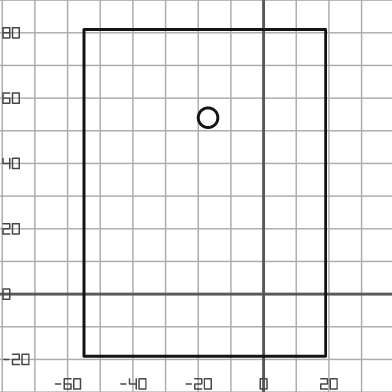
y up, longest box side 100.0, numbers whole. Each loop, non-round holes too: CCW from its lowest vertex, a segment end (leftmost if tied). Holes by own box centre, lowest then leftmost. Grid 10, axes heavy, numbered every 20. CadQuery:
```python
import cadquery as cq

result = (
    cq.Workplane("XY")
    .moveTo(-55.0, -19.0)
    .lineTo(19.0, -19.0)
    .lineTo(19.0, 81.0)
    .lineTo(-55.0, 81.0)
    .close()
    .moveTo(-17.0, 54.0)
    .circle(3.0)
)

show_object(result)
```